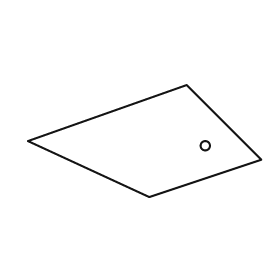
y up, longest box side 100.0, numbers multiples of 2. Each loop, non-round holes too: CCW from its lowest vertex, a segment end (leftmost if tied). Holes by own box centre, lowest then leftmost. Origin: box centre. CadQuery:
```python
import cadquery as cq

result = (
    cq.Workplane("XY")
    .moveTo(2.0, -24.0)
    .lineTo(50.0, -8.0)
    .lineTo(18.0, 24.0)
    .lineTo(-50.0, 0.0)
    .close()
    .moveTo(26.0, -2.0)
    .circle(2.0)
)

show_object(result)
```